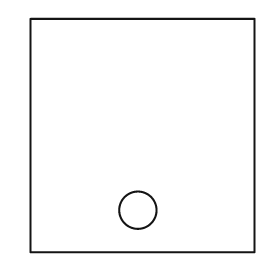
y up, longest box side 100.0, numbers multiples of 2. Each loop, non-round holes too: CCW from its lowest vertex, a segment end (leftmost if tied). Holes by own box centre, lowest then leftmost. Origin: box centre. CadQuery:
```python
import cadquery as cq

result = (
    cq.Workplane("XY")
    .moveTo(-48.0, -50.0)
    .lineTo(48.0, -50.0)
    .lineTo(48.0, 50.0)
    .lineTo(-48.0, 50.0)
    .close()
    .moveTo(-2.0, -32.0)
    .circle(8.0)
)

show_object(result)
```